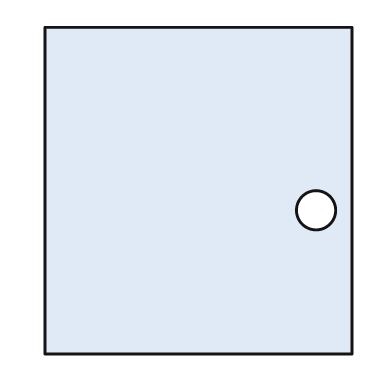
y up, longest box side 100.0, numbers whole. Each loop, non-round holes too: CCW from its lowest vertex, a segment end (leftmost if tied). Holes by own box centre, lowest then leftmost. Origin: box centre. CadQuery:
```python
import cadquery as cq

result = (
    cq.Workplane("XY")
    .moveTo(-47.0, -50.0)
    .lineTo(47.0, -50.0)
    .lineTo(47.0, 50.0)
    .lineTo(-47.0, 50.0)
    .close()
    .moveTo(36.0, -6.0)
    .circle(6.0)
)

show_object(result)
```